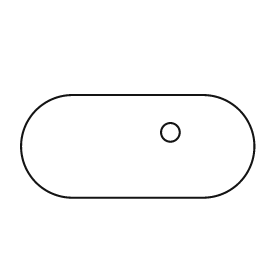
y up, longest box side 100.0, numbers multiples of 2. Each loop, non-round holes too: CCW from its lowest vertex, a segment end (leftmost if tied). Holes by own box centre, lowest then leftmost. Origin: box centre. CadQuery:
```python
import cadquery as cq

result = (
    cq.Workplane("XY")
    .moveTo(-28.0, -22.0)
    .lineTo(28.0, -22.0)
    .threePointArc((50.0, 0.0), (28.0, 22.0))
    .lineTo(-28.0, 22.0)
    .threePointArc((-50.0, 0.0), (-28.0, -22.0))
    .close()
    .moveTo(14.0, 6.0)
    .circle(4.0)
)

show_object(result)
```